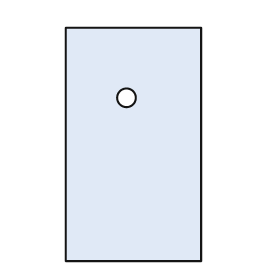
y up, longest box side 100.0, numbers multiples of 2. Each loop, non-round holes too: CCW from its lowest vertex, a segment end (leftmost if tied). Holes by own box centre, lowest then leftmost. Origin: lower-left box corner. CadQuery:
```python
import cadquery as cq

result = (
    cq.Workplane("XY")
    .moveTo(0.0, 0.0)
    .lineTo(58.0, 0.0)
    .lineTo(58.0, 100.0)
    .lineTo(0.0, 100.0)
    .close()
    .moveTo(26.0, 70.0)
    .circle(4.0)
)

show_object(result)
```